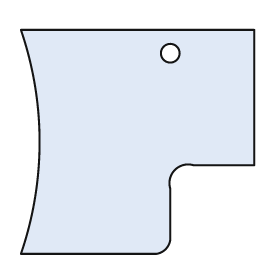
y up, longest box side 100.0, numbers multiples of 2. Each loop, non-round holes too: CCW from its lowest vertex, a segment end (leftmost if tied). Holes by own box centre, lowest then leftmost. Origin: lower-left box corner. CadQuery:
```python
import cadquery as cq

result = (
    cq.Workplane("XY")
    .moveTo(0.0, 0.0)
    .lineTo(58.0, 0.0)
    .threePointArc((62.0, 2.0), (64.0, 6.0))
    .lineTo(64.0, 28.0)
    .threePointArc((66.0, 36.0), (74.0, 38.0))
    .lineTo(100.0, 38.0)
    .lineTo(100.0, 96.0)
    .lineTo(0.0, 96.0)
    .threePointArc((8.0, 48.0), (0.0, 0.0))
    .close()
    .moveTo(64.0, 86.0)
    .circle(4.0)
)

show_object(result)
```